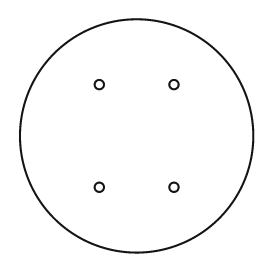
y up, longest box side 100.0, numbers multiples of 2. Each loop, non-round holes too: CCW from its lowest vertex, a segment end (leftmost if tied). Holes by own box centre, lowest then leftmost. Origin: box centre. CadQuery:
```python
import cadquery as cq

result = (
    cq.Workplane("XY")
    .moveTo(0.0, 0.0)
    .circle(50.0)
    .moveTo(-16.0, -22.0)
    .circle(2.0)
    .moveTo(16.0, -22.0)
    .circle(2.0)
    .moveTo(-16.0, 22.0)
    .circle(2.0)
    .moveTo(16.0, 22.0)
    .circle(2.0)
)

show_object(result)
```